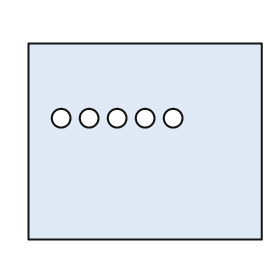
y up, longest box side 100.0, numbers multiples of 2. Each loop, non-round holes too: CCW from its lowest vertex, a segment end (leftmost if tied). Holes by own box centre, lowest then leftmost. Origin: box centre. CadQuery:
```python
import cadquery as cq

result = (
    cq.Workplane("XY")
    .moveTo(-50.0, -42.0)
    .lineTo(50.0, -42.0)
    .lineTo(50.0, 42.0)
    .lineTo(-50.0, 42.0)
    .close()
    .moveTo(-36.0, 10.0)
    .circle(4.0)
    .moveTo(-24.0, 10.0)
    .circle(4.0)
    .moveTo(-12.0, 10.0)
    .circle(4.0)
    .moveTo(0.0, 10.0)
    .circle(4.0)
    .moveTo(12.0, 10.0)
    .circle(4.0)
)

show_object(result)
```